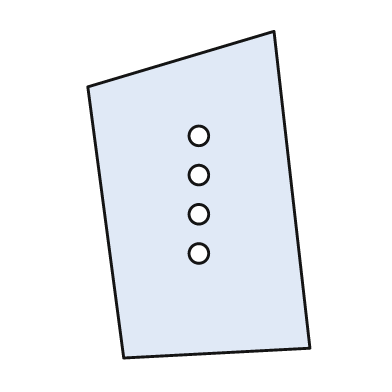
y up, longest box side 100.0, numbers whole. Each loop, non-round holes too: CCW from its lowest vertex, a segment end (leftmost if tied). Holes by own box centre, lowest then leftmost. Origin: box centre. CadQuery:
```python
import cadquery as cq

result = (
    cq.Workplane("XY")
    .moveTo(-23.0, -50.0)
    .lineTo(34.0, -47.0)
    .lineTo(23.0, 50.0)
    .lineTo(-34.0, 33.0)
    .close()
    .moveTo(0.0, -18.0)
    .circle(3.0)
    .moveTo(0.0, -6.0)
    .circle(3.0)
    .moveTo(0.0, 6.0)
    .circle(3.0)
    .moveTo(0.0, 18.0)
    .circle(3.0)
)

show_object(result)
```